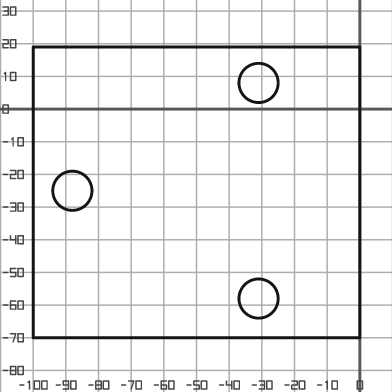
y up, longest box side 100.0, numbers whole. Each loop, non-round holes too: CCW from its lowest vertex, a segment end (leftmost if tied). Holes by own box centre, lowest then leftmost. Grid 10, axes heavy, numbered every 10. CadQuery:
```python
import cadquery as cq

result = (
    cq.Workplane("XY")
    .moveTo(-100.0, -70.0)
    .lineTo(0.0, -70.0)
    .lineTo(0.0, 19.0)
    .lineTo(-100.0, 19.0)
    .close()
    .moveTo(-31.0, -58.0)
    .circle(6.0)
    .moveTo(-88.0, -25.0)
    .circle(6.0)
    .moveTo(-31.0, 8.0)
    .circle(6.0)
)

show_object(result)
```